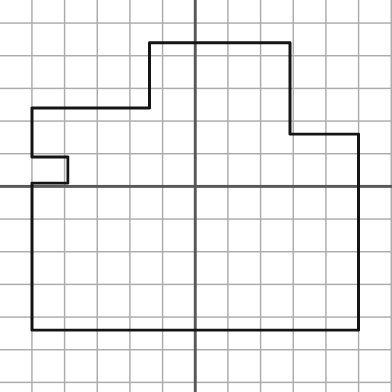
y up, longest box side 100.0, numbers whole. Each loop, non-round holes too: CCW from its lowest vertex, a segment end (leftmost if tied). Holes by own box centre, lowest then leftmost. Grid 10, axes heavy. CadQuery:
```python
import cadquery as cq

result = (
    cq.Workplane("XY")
    .moveTo(-50.0, -44.0)
    .lineTo(50.0, -44.0)
    .lineTo(50.0, 16.0)
    .lineTo(29.0, 16.0)
    .lineTo(29.0, 44.0)
    .lineTo(-14.0, 44.0)
    .lineTo(-14.0, 24.0)
    .lineTo(-50.0, 24.0)
    .lineTo(-50.0, 9.0)
    .lineTo(-39.0, 9.0)
    .lineTo(-39.0, 1.0)
    .lineTo(-50.0, 1.0)
    .close()
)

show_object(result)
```